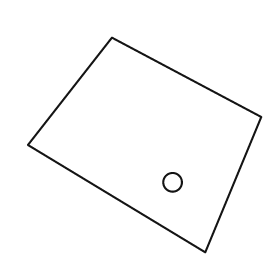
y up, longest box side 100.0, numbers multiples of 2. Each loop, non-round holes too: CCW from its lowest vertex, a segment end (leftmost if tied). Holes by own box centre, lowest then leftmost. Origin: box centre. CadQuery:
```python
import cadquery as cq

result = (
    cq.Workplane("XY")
    .moveTo(26.0, -46.0)
    .lineTo(50.0, 12.0)
    .lineTo(-14.0, 46.0)
    .lineTo(-50.0, 0.0)
    .close()
    .moveTo(12.0, -16.0)
    .circle(4.0)
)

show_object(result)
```